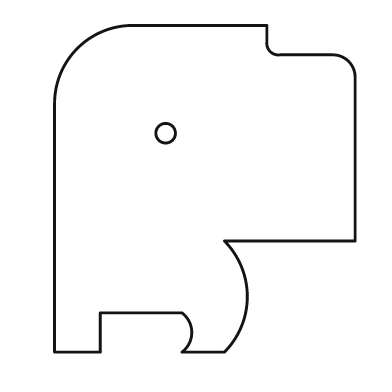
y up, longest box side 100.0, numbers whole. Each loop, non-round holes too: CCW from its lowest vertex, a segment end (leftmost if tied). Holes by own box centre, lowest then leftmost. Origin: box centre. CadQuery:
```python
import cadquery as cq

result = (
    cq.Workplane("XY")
    .moveTo(-46.0, -50.0)
    .lineTo(-32.0, -50.0)
    .lineTo(-32.0, -38.0)
    .lineTo(-7.0, -38.0)
    .threePointArc((-4.0, -44.0), (-7.0, -50.0))
    .lineTo(6.0, -50.0)
    .threePointArc((13.0, -33.0), (6.0, -16.0))
    .lineTo(46.0, -16.0)
    .lineTo(46.0, 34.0)
    .threePointArc((44.0, 39.0), (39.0, 41.0))
    .lineTo(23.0, 41.0)
    .threePointArc((20.0, 42.0), (19.0, 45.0))
    .lineTo(19.0, 50.0)
    .lineTo(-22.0, 50.0)
    .threePointArc((-39.0, 43.0), (-46.0, 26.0))
    .close()
    .moveTo(-12.0, 17.0)
    .circle(3.0)
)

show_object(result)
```